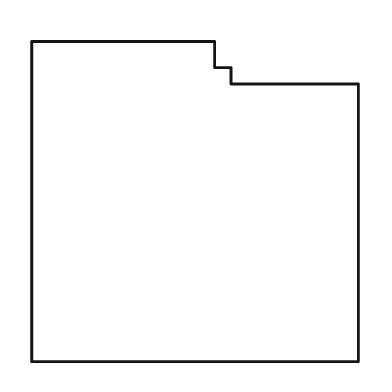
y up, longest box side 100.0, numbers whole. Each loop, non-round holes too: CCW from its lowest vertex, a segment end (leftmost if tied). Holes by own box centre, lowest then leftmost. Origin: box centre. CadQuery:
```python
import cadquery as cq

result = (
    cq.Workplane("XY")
    .moveTo(-50.0, -49.0)
    .lineTo(50.0, -49.0)
    .lineTo(50.0, 36.0)
    .lineTo(11.0, 36.0)
    .lineTo(11.0, 41.0)
    .lineTo(6.0, 41.0)
    .lineTo(6.0, 49.0)
    .lineTo(-50.0, 49.0)
    .close()
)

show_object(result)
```